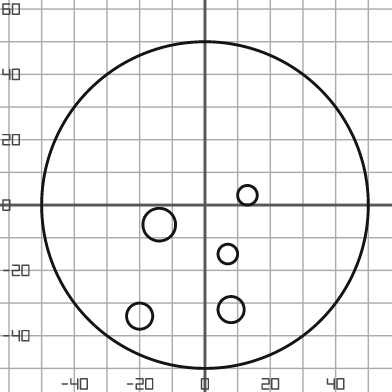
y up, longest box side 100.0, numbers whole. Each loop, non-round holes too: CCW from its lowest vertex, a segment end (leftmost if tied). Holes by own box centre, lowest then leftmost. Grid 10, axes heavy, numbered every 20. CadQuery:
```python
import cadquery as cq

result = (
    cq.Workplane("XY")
    .moveTo(0.0, 0.0)
    .circle(50.0)
    .moveTo(-20.0, -34.0)
    .circle(4.0)
    .moveTo(8.0, -32.0)
    .circle(4.0)
    .moveTo(7.0, -15.0)
    .circle(3.0)
    .moveTo(-14.0, -6.0)
    .circle(5.0)
    .moveTo(13.0, 3.0)
    .circle(3.0)
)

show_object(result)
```